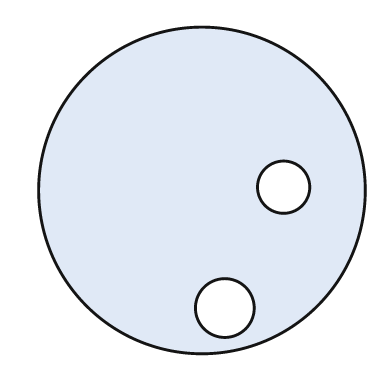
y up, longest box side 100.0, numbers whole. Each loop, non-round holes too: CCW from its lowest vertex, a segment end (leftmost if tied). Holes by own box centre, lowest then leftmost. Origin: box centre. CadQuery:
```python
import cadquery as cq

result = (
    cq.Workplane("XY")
    .moveTo(0.0, 0.0)
    .circle(50.0)
    .moveTo(7.0, -36.0)
    .circle(9.0)
    .moveTo(25.0, 1.0)
    .circle(8.0)
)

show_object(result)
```